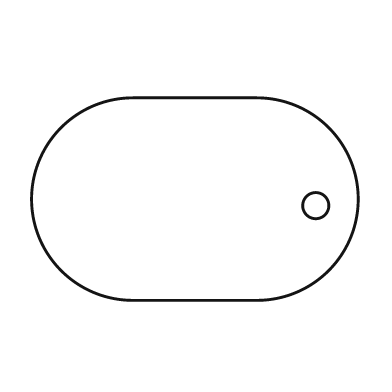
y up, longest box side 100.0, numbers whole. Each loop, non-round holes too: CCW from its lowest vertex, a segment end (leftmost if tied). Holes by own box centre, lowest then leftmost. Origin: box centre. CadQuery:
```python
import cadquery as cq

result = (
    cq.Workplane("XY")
    .moveTo(-19.0, -31.0)
    .lineTo(19.0, -31.0)
    .threePointArc((50.0, 0.0), (19.0, 31.0))
    .lineTo(-19.0, 31.0)
    .threePointArc((-50.0, 0.0), (-19.0, -31.0))
    .close()
    .moveTo(37.0, -2.0)
    .circle(4.0)
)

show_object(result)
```